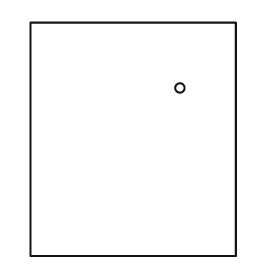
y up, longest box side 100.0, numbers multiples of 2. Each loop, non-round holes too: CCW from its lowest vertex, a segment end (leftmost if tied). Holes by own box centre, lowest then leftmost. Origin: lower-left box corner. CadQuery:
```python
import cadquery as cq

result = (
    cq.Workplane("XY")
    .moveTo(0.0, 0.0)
    .lineTo(88.0, 0.0)
    .lineTo(88.0, 100.0)
    .lineTo(0.0, 100.0)
    .close()
    .moveTo(64.0, 72.0)
    .circle(2.0)
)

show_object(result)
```